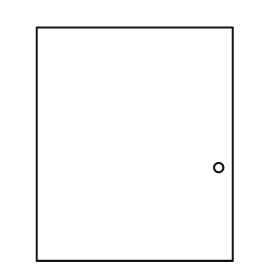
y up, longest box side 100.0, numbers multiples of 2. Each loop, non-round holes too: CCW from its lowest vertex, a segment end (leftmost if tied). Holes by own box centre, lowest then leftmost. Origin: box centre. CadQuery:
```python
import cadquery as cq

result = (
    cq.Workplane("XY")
    .moveTo(-42.0, -50.0)
    .lineTo(42.0, -50.0)
    .lineTo(42.0, 50.0)
    .lineTo(-42.0, 50.0)
    .close()
    .moveTo(36.0, -10.0)
    .circle(2.0)
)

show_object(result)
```